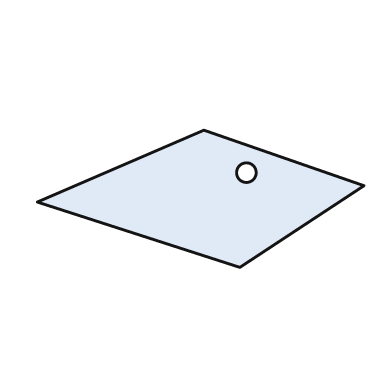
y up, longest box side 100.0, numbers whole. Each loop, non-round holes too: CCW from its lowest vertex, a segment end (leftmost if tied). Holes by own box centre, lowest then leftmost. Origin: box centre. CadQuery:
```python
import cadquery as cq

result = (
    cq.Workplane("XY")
    .moveTo(12.0, -21.0)
    .lineTo(50.0, 4.0)
    .lineTo(1.0, 21.0)
    .lineTo(-50.0, -1.0)
    .close()
    .moveTo(14.0, 8.0)
    .circle(3.0)
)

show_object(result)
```